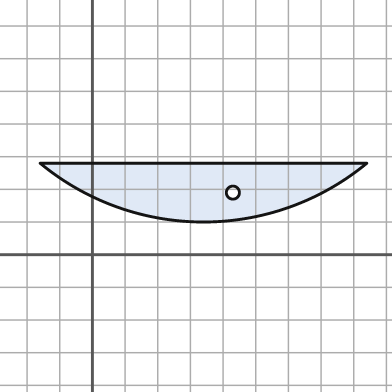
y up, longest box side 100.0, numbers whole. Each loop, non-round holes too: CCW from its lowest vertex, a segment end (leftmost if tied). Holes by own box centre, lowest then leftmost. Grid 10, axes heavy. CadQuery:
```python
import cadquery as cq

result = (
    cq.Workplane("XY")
    .moveTo(-16.0, 28.0)
    .threePointArc((34.0, 10.0), (84.0, 28.0))
    .close()
    .moveTo(43.0, 19.0)
    .circle(2.0)
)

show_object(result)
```